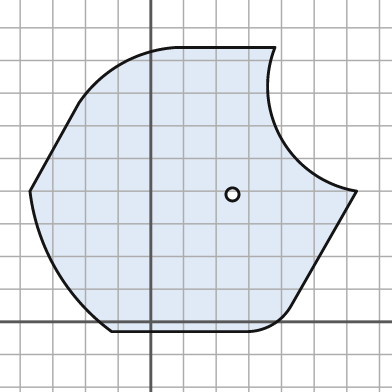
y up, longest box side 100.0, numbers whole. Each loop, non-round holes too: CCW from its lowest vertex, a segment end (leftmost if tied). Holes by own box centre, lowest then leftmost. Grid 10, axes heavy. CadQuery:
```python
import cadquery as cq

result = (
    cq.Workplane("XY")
    .moveTo(-12.0, -3.0)
    .lineTo(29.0, -3.0)
    .threePointArc((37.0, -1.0), (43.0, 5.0))
    .lineTo(63.0, 40.0)
    .threePointArc((40.0, 56.0), (38.0, 84.0))
    .lineTo(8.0, 84.0)
    .threePointArc((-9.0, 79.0), (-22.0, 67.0))
    .lineTo(-37.0, 40.0)
    .threePointArc((-29.0, 16.0), (-12.0, -3.0))
    .close()
    .moveTo(25.0, 39.0)
    .circle(2.0)
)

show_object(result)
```